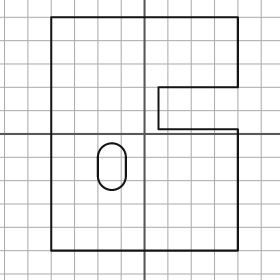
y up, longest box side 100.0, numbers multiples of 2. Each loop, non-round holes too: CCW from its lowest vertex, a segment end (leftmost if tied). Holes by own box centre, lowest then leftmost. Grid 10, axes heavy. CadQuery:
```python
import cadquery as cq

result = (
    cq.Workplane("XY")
    .moveTo(-40.0, -50.0)
    .lineTo(40.0, -50.0)
    .lineTo(40.0, 2.0)
    .lineTo(6.0, 2.0)
    .lineTo(6.0, 20.0)
    .lineTo(40.0, 20.0)
    .lineTo(40.0, 50.0)
    .lineTo(-40.0, 50.0)
    .close()
    .moveTo(-20.0, -18.0)
    .threePointArc((-14.0, -24.0), (-8.0, -18.0))
    .lineTo(-8.0, -10.0)
    .threePointArc((-14.0, -4.0), (-20.0, -10.0))
    .close()
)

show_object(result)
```